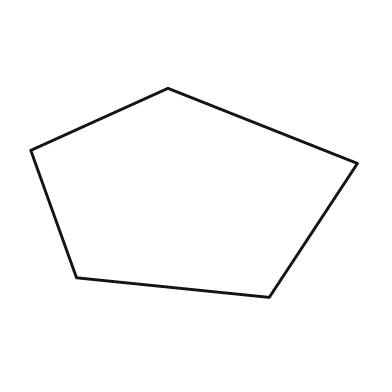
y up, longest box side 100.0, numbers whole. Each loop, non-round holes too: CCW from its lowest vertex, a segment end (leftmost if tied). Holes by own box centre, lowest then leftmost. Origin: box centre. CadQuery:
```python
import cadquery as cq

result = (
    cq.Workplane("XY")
    .moveTo(23.0, -32.0)
    .lineTo(50.0, 9.0)
    .lineTo(-8.0, 32.0)
    .lineTo(-50.0, 13.0)
    .lineTo(-36.0, -26.0)
    .close()
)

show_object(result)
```